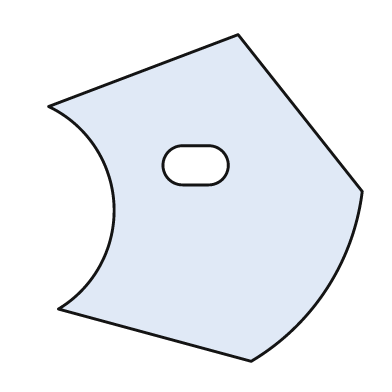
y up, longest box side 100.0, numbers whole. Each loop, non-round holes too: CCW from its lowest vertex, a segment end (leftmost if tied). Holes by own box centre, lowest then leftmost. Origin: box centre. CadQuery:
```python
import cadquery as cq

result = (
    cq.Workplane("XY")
    .moveTo(14.0, -50.0)
    .threePointArc((37.0, -28.0), (48.0, 2.0))
    .lineTo(10.0, 50.0)
    .lineTo(-48.0, 28.0)
    .threePointArc((-28.0, -2.0), (-45.0, -34.0))
    .close()
    .moveTo(-7.0, 4.0)
    .lineTo(1.0, 4.0)
    .threePointArc((7.0, 10.0), (1.0, 16.0))
    .lineTo(-7.0, 16.0)
    .threePointArc((-13.0, 10.0), (-7.0, 4.0))
    .close()
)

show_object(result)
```